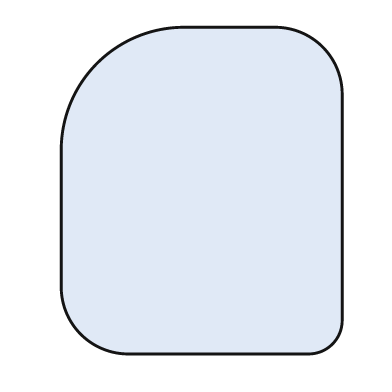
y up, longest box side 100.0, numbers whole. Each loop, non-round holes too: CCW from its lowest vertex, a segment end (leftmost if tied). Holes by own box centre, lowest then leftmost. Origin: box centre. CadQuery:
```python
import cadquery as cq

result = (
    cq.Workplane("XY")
    .moveTo(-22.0, -50.0)
    .lineTo(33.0, -50.0)
    .threePointArc((40.0, -47.0), (43.0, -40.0))
    .lineTo(43.0, 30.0)
    .threePointArc((37.0, 44.0), (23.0, 50.0))
    .lineTo(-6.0, 50.0)
    .threePointArc((-32.0, 39.0), (-43.0, 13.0))
    .lineTo(-43.0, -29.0)
    .threePointArc((-37.0, -44.0), (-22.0, -50.0))
    .close()
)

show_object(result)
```